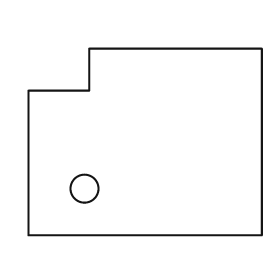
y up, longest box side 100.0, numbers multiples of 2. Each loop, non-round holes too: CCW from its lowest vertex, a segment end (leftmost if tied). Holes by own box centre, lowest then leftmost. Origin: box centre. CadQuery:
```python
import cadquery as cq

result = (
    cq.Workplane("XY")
    .moveTo(-50.0, -40.0)
    .lineTo(50.0, -40.0)
    .lineTo(50.0, 40.0)
    .lineTo(-24.0, 40.0)
    .lineTo(-24.0, 22.0)
    .lineTo(-50.0, 22.0)
    .close()
    .moveTo(-26.0, -20.0)
    .circle(6.0)
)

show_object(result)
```